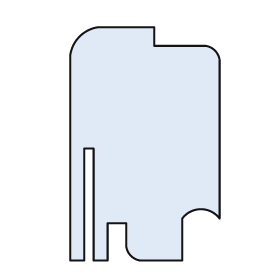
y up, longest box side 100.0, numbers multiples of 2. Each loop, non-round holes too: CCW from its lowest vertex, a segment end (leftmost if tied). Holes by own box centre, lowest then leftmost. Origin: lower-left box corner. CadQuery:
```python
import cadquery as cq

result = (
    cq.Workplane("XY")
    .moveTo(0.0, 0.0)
    .lineTo(6.0, 0.0)
    .lineTo(6.0, 48.0)
    .lineTo(10.0, 48.0)
    .lineTo(10.0, 0.0)
    .lineTo(16.0, 0.0)
    .lineTo(16.0, 16.0)
    .lineTo(24.0, 16.0)
    .lineTo(24.0, 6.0)
    .threePointArc((26.0, 2.0), (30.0, 0.0))
    .lineTo(48.0, 0.0)
    .lineTo(48.0, 18.0)
    .threePointArc((56.0, 22.0), (64.0, 18.0))
    .lineTo(64.0, 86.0)
    .threePointArc((62.0, 90.0), (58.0, 92.0))
    .lineTo(36.0, 92.0)
    .lineTo(36.0, 100.0)
    .lineTo(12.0, 100.0)
    .threePointArc((4.0, 96.0), (0.0, 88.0))
    .close()
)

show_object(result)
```